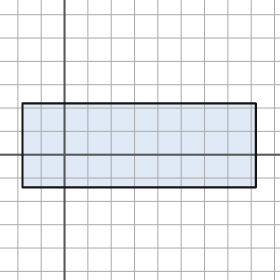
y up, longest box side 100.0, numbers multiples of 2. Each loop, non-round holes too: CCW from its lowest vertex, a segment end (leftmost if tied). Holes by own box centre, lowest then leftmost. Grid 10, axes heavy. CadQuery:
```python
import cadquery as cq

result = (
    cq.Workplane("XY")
    .moveTo(-18.0, -14.0)
    .lineTo(82.0, -14.0)
    .lineTo(82.0, 22.0)
    .lineTo(-18.0, 22.0)
    .close()
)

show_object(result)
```